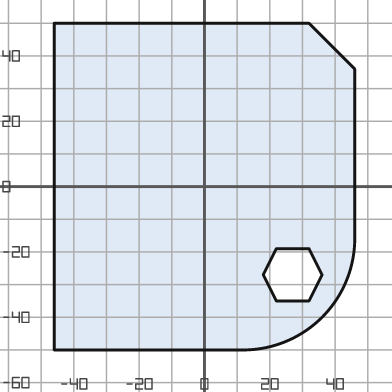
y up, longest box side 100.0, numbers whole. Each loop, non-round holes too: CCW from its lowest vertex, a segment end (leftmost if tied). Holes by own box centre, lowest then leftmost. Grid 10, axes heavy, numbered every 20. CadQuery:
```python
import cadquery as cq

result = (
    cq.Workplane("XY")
    .moveTo(-46.0, -50.0)
    .lineTo(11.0, -50.0)
    .threePointArc((36.0, -40.0), (46.0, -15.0))
    .lineTo(46.0, 36.0)
    .lineTo(32.0, 50.0)
    .lineTo(-46.0, 50.0)
    .close()
    .moveTo(22.0, -35.0)
    .lineTo(32.0, -35.0)
    .lineTo(36.0, -27.0)
    .lineTo(32.0, -19.0)
    .lineTo(22.0, -19.0)
    .lineTo(18.0, -27.0)
    .close()
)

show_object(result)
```